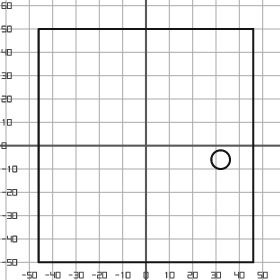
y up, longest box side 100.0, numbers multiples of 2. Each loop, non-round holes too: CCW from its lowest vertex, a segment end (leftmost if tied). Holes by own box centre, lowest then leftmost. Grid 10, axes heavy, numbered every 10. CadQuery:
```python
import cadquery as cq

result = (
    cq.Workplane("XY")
    .moveTo(-46.0, -50.0)
    .lineTo(46.0, -50.0)
    .lineTo(46.0, 50.0)
    .lineTo(-46.0, 50.0)
    .close()
    .moveTo(32.0, -6.0)
    .circle(4.0)
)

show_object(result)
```